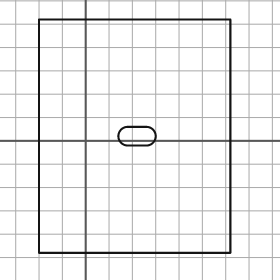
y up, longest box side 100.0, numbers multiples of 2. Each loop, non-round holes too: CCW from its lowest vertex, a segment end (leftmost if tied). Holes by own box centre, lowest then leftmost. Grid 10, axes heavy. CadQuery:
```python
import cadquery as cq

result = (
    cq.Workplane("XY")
    .moveTo(-20.0, -48.0)
    .lineTo(62.0, -48.0)
    .lineTo(62.0, 52.0)
    .lineTo(-20.0, 52.0)
    .close()
    .moveTo(18.0, -2.0)
    .lineTo(26.0, -2.0)
    .threePointArc((30.0, 2.0), (26.0, 6.0))
    .lineTo(18.0, 6.0)
    .threePointArc((14.0, 2.0), (18.0, -2.0))
    .close()
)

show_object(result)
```